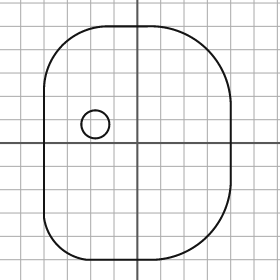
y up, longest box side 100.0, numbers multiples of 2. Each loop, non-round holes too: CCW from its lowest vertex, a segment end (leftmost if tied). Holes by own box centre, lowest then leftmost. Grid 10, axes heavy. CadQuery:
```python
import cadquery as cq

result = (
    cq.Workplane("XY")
    .moveTo(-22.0, -50.0)
    .lineTo(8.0, -50.0)
    .threePointArc((30.0, -40.0), (40.0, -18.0))
    .lineTo(40.0, 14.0)
    .threePointArc((30.0, 40.0), (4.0, 50.0))
    .lineTo(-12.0, 50.0)
    .threePointArc((-32.0, 42.0), (-40.0, 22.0))
    .lineTo(-40.0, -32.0)
    .threePointArc((-34.0, -44.0), (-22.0, -50.0))
    .close()
    .moveTo(-18.0, 8.0)
    .circle(6.0)
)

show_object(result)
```